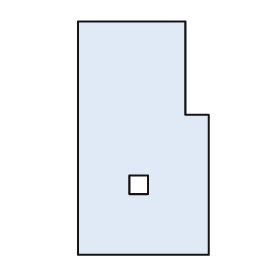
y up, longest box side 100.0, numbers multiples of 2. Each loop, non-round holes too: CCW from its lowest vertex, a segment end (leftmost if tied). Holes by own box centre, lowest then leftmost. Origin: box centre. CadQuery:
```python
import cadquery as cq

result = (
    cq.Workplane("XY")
    .moveTo(-28.0, -50.0)
    .lineTo(28.0, -50.0)
    .lineTo(28.0, 10.0)
    .lineTo(18.0, 10.0)
    .lineTo(18.0, 50.0)
    .lineTo(-28.0, 50.0)
    .close()
    .moveTo(-6.0, -24.0)
    .lineTo(2.0, -24.0)
    .lineTo(2.0, -16.0)
    .lineTo(-6.0, -16.0)
    .close()
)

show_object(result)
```